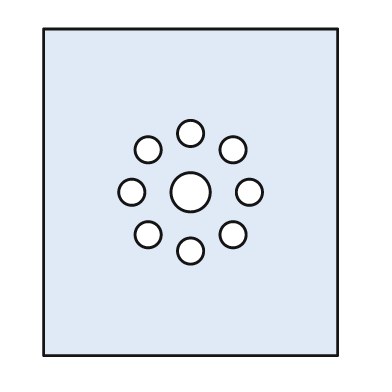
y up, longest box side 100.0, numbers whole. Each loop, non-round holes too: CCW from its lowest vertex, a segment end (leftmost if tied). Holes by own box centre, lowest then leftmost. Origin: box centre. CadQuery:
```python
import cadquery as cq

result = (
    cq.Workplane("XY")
    .moveTo(-45.0, -50.0)
    .lineTo(45.0, -50.0)
    .lineTo(45.0, 50.0)
    .lineTo(-45.0, 50.0)
    .close()
    .moveTo(0.0, -18.0)
    .circle(4.0)
    .moveTo(-13.0, -13.0)
    .circle(4.0)
    .moveTo(13.0, -13.0)
    .circle(4.0)
    .moveTo(-18.0, 0.0)
    .circle(4.0)
    .moveTo(0.0, 0.0)
    .circle(6.0)
    .moveTo(18.0, 0.0)
    .circle(4.0)
    .moveTo(-13.0, 13.0)
    .circle(4.0)
    .moveTo(13.0, 13.0)
    .circle(4.0)
    .moveTo(0.0, 18.0)
    .circle(4.0)
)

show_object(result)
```